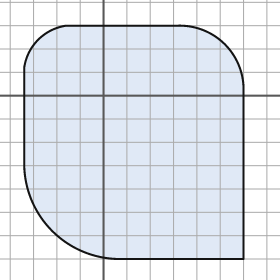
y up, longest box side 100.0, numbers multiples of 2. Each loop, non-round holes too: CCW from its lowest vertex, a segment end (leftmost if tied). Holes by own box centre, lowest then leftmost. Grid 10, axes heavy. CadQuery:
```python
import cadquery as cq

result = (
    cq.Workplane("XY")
    .moveTo(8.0, -70.0)
    .lineTo(60.0, -70.0)
    .lineTo(60.0, 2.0)
    .threePointArc((52.0, 22.0), (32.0, 30.0))
    .lineTo(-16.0, 30.0)
    .threePointArc((-28.0, 24.0), (-34.0, 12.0))
    .lineTo(-34.0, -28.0)
    .threePointArc((-22.0, -58.0), (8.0, -70.0))
    .close()
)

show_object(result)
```